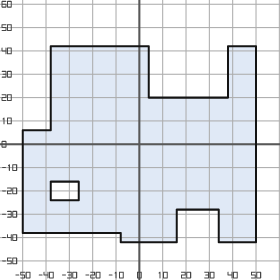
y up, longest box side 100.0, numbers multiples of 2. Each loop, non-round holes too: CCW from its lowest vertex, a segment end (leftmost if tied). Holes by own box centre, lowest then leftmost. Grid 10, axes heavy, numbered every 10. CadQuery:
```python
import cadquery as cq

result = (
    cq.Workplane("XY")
    .moveTo(-8.0, -42.0)
    .lineTo(16.0, -42.0)
    .lineTo(16.0, -28.0)
    .lineTo(34.0, -28.0)
    .lineTo(34.0, -42.0)
    .lineTo(50.0, -42.0)
    .lineTo(50.0, 42.0)
    .lineTo(38.0, 42.0)
    .lineTo(38.0, 20.0)
    .lineTo(4.0, 20.0)
    .lineTo(4.0, 42.0)
    .lineTo(-38.0, 42.0)
    .lineTo(-38.0, 6.0)
    .lineTo(-50.0, 6.0)
    .lineTo(-50.0, -38.0)
    .lineTo(-8.0, -38.0)
    .close()
    .moveTo(-38.0, -24.0)
    .lineTo(-26.0, -24.0)
    .lineTo(-26.0, -16.0)
    .lineTo(-38.0, -16.0)
    .close()
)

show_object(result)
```